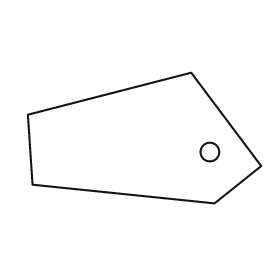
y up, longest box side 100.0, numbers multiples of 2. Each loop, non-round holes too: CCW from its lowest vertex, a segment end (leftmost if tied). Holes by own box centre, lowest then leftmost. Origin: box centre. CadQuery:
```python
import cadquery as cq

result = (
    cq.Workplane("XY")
    .moveTo(30.0, -28.0)
    .lineTo(50.0, -12.0)
    .lineTo(20.0, 28.0)
    .lineTo(-50.0, 10.0)
    .lineTo(-48.0, -20.0)
    .close()
    .moveTo(28.0, -6.0)
    .circle(4.0)
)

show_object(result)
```